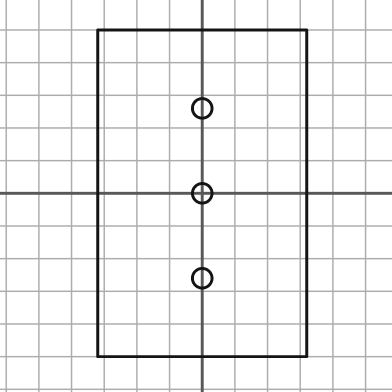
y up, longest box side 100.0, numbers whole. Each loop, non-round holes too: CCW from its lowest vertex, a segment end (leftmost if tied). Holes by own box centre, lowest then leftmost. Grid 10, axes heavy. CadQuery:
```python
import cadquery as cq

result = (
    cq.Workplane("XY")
    .moveTo(-32.0, -50.0)
    .lineTo(32.0, -50.0)
    .lineTo(32.0, 50.0)
    .lineTo(-32.0, 50.0)
    .close()
    .moveTo(0.0, -26.0)
    .circle(3.0)
    .moveTo(0.0, 0.0)
    .circle(3.0)
    .moveTo(0.0, 26.0)
    .circle(3.0)
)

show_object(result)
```